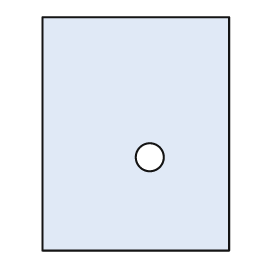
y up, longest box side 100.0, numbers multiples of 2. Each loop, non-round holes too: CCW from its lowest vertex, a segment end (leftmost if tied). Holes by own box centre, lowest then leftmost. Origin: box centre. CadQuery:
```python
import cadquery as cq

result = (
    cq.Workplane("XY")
    .moveTo(-40.0, -50.0)
    .lineTo(40.0, -50.0)
    .lineTo(40.0, 50.0)
    .lineTo(-40.0, 50.0)
    .close()
    .moveTo(6.0, -10.0)
    .circle(6.0)
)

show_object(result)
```